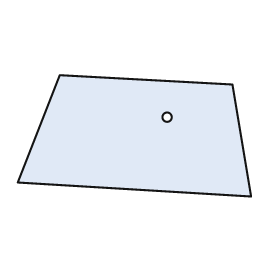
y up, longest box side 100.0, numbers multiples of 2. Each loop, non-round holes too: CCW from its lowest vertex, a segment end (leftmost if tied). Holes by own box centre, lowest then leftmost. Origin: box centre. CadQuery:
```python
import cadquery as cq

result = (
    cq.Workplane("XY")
    .moveTo(50.0, -26.0)
    .lineTo(42.0, 22.0)
    .lineTo(-32.0, 26.0)
    .lineTo(-50.0, -20.0)
    .close()
    .moveTo(14.0, 8.0)
    .circle(2.0)
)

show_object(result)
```